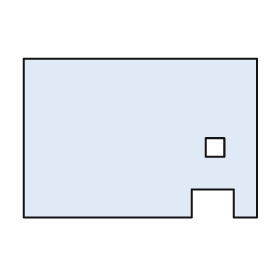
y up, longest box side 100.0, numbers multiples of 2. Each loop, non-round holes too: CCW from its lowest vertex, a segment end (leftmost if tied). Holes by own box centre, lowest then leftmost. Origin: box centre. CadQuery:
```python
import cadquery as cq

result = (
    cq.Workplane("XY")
    .moveTo(-50.0, -34.0)
    .lineTo(22.0, -34.0)
    .lineTo(22.0, -22.0)
    .lineTo(40.0, -22.0)
    .lineTo(40.0, -34.0)
    .lineTo(50.0, -34.0)
    .lineTo(50.0, 34.0)
    .lineTo(-50.0, 34.0)
    .close()
    .moveTo(28.0, -8.0)
    .lineTo(36.0, -8.0)
    .lineTo(36.0, 0.0)
    .lineTo(28.0, 0.0)
    .close()
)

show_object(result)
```